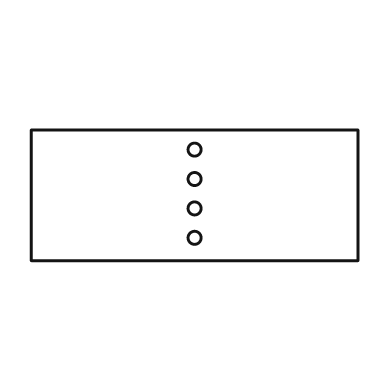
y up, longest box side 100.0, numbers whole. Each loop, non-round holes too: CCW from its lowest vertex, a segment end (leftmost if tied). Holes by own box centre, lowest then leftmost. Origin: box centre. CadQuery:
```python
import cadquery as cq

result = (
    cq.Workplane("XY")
    .moveTo(-50.0, -20.0)
    .lineTo(50.0, -20.0)
    .lineTo(50.0, 20.0)
    .lineTo(-50.0, 20.0)
    .close()
    .moveTo(0.0, -13.0)
    .circle(2.0)
    .moveTo(0.0, -4.0)
    .circle(2.0)
    .moveTo(0.0, 5.0)
    .circle(2.0)
    .moveTo(0.0, 14.0)
    .circle(2.0)
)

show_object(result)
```